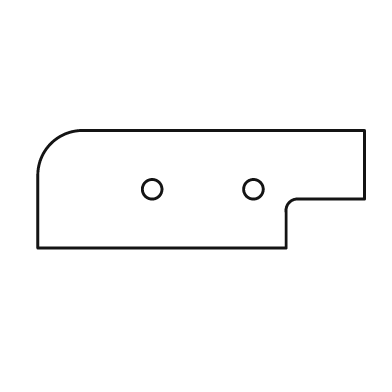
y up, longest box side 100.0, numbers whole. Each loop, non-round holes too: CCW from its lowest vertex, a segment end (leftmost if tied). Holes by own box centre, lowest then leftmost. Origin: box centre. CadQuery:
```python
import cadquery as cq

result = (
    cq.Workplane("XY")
    .moveTo(-50.0, -18.0)
    .lineTo(26.0, -18.0)
    .lineTo(26.0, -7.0)
    .threePointArc((27.0, -4.0), (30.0, -3.0))
    .lineTo(50.0, -3.0)
    .lineTo(50.0, 18.0)
    .lineTo(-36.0, 18.0)
    .threePointArc((-46.0, 14.0), (-50.0, 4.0))
    .close()
    .moveTo(-15.0, 0.0)
    .circle(3.0)
    .moveTo(16.0, 0.0)
    .circle(3.0)
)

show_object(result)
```